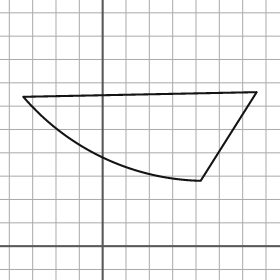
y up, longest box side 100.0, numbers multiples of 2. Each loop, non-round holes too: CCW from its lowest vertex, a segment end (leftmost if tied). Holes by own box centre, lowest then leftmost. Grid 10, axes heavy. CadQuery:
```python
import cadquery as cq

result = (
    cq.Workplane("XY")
    .moveTo(42.0, 28.0)
    .lineTo(66.0, 66.0)
    .lineTo(-34.0, 64.0)
    .threePointArc((0.0, 38.0), (42.0, 28.0))
    .close()
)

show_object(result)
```